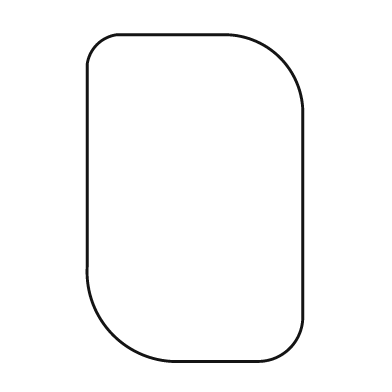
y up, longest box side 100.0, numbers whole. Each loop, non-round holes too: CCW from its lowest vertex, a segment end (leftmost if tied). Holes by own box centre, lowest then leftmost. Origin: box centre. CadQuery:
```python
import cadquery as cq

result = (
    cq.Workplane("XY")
    .moveTo(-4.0, -50.0)
    .lineTo(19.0, -50.0)
    .threePointArc((29.0, -46.0), (33.0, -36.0))
    .lineTo(33.0, 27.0)
    .threePointArc((26.0, 43.0), (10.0, 50.0))
    .lineTo(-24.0, 50.0)
    .threePointArc((-30.0, 47.0), (-33.0, 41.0))
    .lineTo(-33.0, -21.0)
    .threePointArc((-25.0, -42.0), (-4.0, -50.0))
    .close()
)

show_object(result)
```